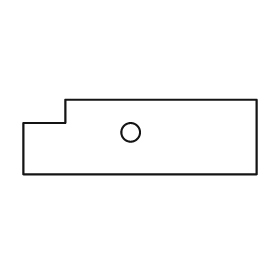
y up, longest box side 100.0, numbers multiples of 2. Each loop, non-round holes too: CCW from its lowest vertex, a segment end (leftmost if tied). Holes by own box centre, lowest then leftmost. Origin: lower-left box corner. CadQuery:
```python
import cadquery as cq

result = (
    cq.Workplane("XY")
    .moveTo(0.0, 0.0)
    .lineTo(100.0, 0.0)
    .lineTo(100.0, 32.0)
    .lineTo(18.0, 32.0)
    .lineTo(18.0, 22.0)
    .lineTo(0.0, 22.0)
    .close()
    .moveTo(46.0, 18.0)
    .circle(4.0)
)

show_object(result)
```